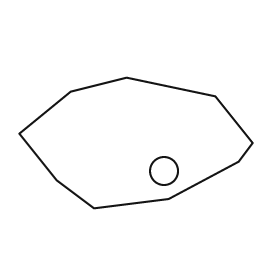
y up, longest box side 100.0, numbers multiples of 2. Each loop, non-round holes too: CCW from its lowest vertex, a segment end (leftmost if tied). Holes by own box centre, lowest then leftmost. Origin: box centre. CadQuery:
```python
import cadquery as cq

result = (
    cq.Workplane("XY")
    .moveTo(-18.0, -28.0)
    .lineTo(14.0, -24.0)
    .lineTo(44.0, -8.0)
    .lineTo(50.0, 0.0)
    .lineTo(34.0, 20.0)
    .lineTo(-4.0, 28.0)
    .lineTo(-28.0, 22.0)
    .lineTo(-50.0, 4.0)
    .lineTo(-34.0, -16.0)
    .close()
    .moveTo(12.0, -12.0)
    .circle(6.0)
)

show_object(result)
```